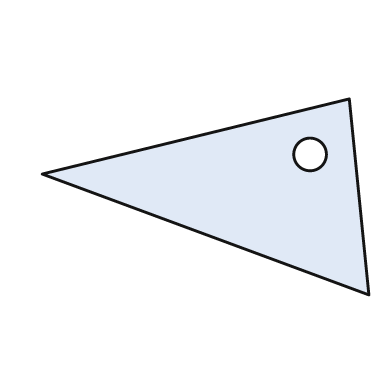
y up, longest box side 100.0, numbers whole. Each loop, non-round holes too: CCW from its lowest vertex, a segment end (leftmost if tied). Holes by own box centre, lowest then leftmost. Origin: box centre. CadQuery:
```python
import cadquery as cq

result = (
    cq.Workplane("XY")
    .moveTo(50.0, -30.0)
    .lineTo(44.0, 30.0)
    .lineTo(-50.0, 7.0)
    .close()
    .moveTo(32.0, 13.0)
    .circle(5.0)
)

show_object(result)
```